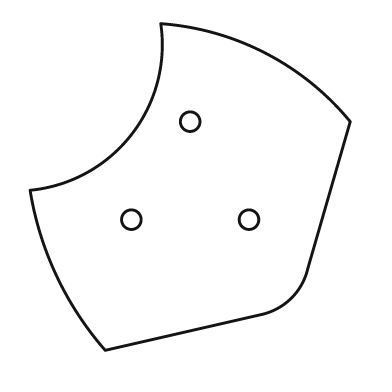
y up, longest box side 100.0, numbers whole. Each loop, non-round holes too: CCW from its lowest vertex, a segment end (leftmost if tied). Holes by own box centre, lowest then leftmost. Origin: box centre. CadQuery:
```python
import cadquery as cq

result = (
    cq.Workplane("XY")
    .moveTo(-26.0, -50.0)
    .lineTo(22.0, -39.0)
    .threePointArc((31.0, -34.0), (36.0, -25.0))
    .lineTo(49.0, 20.0)
    .threePointArc((23.0, 41.0), (-9.0, 50.0))
    .threePointArc((-18.0, 16.0), (-49.0, -1.0))
    .threePointArc((-41.0, -27.0), (-26.0, -50.0))
    .close()
    .moveTo(-18.0, -10.0)
    .circle(3.0)
    .moveTo(18.0, -10.0)
    .circle(3.0)
    .moveTo(0.0, 20.0)
    .circle(3.0)
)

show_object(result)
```